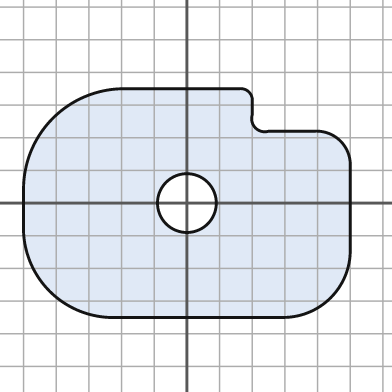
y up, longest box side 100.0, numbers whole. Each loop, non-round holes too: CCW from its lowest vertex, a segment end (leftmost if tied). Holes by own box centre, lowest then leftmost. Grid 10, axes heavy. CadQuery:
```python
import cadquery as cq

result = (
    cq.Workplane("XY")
    .moveTo(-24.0, -35.0)
    .lineTo(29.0, -35.0)
    .threePointArc((44.0, -29.0), (50.0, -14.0))
    .lineTo(50.0, 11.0)
    .threePointArc((47.0, 19.0), (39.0, 22.0))
    .lineTo(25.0, 22.0)
    .threePointArc((21.0, 23.0), (20.0, 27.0))
    .lineTo(20.0, 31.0)
    .threePointArc((19.0, 34.0), (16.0, 35.0))
    .lineTo(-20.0, 35.0)
    .threePointArc((-41.0, 26.0), (-50.0, 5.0))
    .lineTo(-50.0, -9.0)
    .threePointArc((-42.0, -27.0), (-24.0, -35.0))
    .close()
    .moveTo(0.0, 0.0)
    .circle(9.0)
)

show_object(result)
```